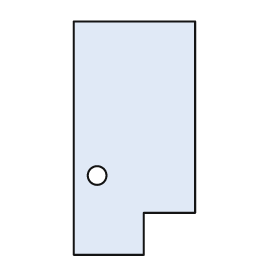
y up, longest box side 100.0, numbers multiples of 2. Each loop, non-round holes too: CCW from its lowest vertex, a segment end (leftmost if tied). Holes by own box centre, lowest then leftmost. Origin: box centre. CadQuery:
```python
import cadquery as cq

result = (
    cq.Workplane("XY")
    .moveTo(-26.0, -50.0)
    .lineTo(4.0, -50.0)
    .lineTo(4.0, -32.0)
    .lineTo(26.0, -32.0)
    .lineTo(26.0, 50.0)
    .lineTo(-26.0, 50.0)
    .close()
    .moveTo(-16.0, -16.0)
    .circle(4.0)
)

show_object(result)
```